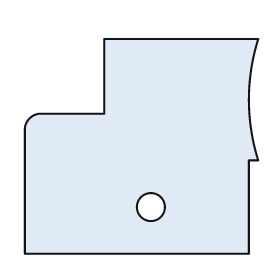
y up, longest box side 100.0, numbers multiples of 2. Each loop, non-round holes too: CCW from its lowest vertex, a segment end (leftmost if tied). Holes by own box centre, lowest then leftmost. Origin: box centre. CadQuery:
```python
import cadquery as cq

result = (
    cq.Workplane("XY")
    .moveTo(-50.0, -46.0)
    .lineTo(46.0, -46.0)
    .lineTo(46.0, -6.0)
    .lineTo(50.0, -6.0)
    .threePointArc((46.0, 20.0), (50.0, 46.0))
    .lineTo(-16.0, 46.0)
    .lineTo(-16.0, 14.0)
    .lineTo(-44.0, 14.0)
    .threePointArc((-48.0, 12.0), (-50.0, 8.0))
    .close()
    .moveTo(4.0, -26.0)
    .circle(6.0)
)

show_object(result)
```